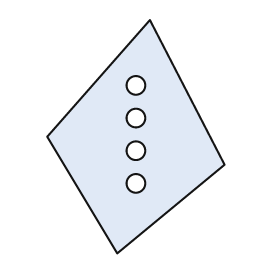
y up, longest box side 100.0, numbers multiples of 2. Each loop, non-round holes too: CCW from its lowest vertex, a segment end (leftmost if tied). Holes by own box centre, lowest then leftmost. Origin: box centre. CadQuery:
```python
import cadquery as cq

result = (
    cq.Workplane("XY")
    .moveTo(-8.0, -50.0)
    .lineTo(38.0, -12.0)
    .lineTo(6.0, 50.0)
    .lineTo(-38.0, 0.0)
    .close()
    .moveTo(0.0, -20.0)
    .circle(4.0)
    .moveTo(0.0, -6.0)
    .circle(4.0)
    .moveTo(0.0, 8.0)
    .circle(4.0)
    .moveTo(0.0, 22.0)
    .circle(4.0)
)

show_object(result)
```